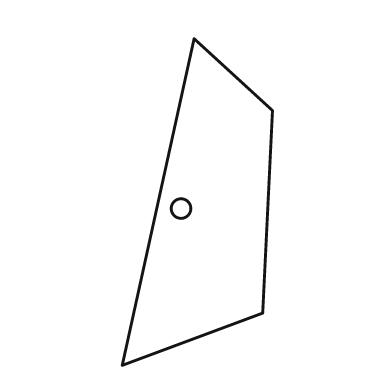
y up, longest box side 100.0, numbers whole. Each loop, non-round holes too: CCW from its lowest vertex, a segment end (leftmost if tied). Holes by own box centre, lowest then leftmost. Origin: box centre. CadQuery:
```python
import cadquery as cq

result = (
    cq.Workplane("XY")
    .moveTo(-23.0, -50.0)
    .lineTo(20.0, -34.0)
    .lineTo(23.0, 28.0)
    .lineTo(-1.0, 50.0)
    .close()
    .moveTo(-5.0, -2.0)
    .circle(3.0)
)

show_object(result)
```